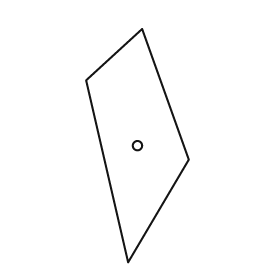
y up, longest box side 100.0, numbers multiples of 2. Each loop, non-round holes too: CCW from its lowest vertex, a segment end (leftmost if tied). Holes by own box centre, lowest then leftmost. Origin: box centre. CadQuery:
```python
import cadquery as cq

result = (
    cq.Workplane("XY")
    .moveTo(-4.0, -50.0)
    .lineTo(22.0, -6.0)
    .lineTo(2.0, 50.0)
    .lineTo(-22.0, 28.0)
    .close()
    .moveTo(0.0, 0.0)
    .circle(2.0)
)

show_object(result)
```